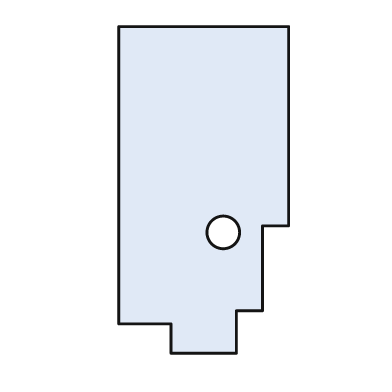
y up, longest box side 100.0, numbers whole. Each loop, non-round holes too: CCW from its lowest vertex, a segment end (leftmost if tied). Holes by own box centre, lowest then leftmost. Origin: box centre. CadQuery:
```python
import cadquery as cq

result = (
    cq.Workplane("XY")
    .moveTo(-10.0, -50.0)
    .lineTo(10.0, -50.0)
    .lineTo(10.0, -37.0)
    .lineTo(18.0, -37.0)
    .lineTo(18.0, -11.0)
    .lineTo(26.0, -11.0)
    .lineTo(26.0, 50.0)
    .lineTo(-26.0, 50.0)
    .lineTo(-26.0, -41.0)
    .lineTo(-10.0, -41.0)
    .close()
    .moveTo(6.0, -13.0)
    .circle(5.0)
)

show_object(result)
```